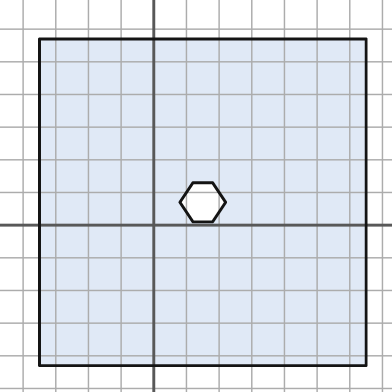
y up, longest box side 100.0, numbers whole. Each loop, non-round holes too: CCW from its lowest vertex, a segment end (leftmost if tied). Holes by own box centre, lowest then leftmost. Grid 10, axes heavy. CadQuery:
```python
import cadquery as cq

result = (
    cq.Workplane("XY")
    .moveTo(-35.0, -43.0)
    .lineTo(65.0, -43.0)
    .lineTo(65.0, 57.0)
    .lineTo(-35.0, 57.0)
    .close()
    .moveTo(12.0, 1.0)
    .lineTo(18.0, 1.0)
    .lineTo(22.0, 7.0)
    .lineTo(18.0, 13.0)
    .lineTo(12.0, 13.0)
    .lineTo(8.0, 7.0)
    .close()
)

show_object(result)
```